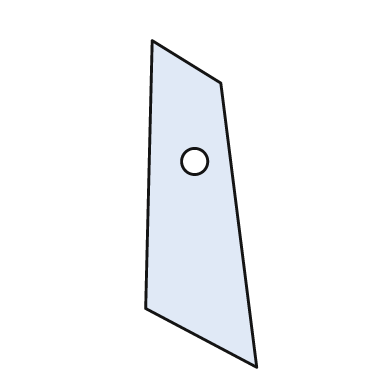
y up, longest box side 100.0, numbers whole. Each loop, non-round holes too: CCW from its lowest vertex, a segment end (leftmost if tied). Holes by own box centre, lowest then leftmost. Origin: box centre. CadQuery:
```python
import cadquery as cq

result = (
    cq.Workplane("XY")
    .moveTo(17.0, -50.0)
    .lineTo(6.0, 37.0)
    .lineTo(-15.0, 50.0)
    .lineTo(-17.0, -32.0)
    .close()
    .moveTo(-2.0, 13.0)
    .circle(4.0)
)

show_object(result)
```